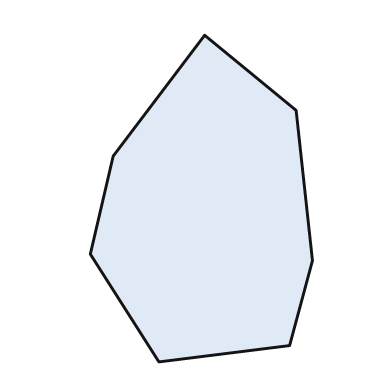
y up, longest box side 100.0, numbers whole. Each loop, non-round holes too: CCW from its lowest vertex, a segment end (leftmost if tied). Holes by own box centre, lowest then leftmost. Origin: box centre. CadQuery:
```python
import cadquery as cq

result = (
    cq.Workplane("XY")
    .moveTo(-13.0, -50.0)
    .lineTo(27.0, -45.0)
    .lineTo(34.0, -19.0)
    .lineTo(29.0, 27.0)
    .lineTo(1.0, 50.0)
    .lineTo(-27.0, 13.0)
    .lineTo(-34.0, -17.0)
    .close()
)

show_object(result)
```